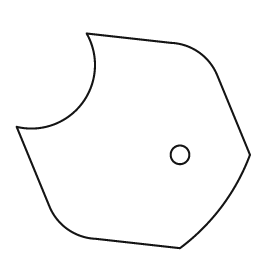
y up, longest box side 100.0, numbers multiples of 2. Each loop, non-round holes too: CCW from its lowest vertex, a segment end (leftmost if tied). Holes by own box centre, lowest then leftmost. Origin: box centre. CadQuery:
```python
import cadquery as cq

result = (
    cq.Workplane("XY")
    .moveTo(20.0, -46.0)
    .threePointArc((38.0, -28.0), (50.0, -6.0))
    .lineTo(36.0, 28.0)
    .threePointArc((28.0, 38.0), (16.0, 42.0))
    .lineTo(-20.0, 46.0)
    .threePointArc((-22.0, 16.0), (-50.0, 6.0))
    .lineTo(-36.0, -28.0)
    .threePointArc((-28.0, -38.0), (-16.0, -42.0))
    .close()
    .moveTo(20.0, -6.0)
    .circle(4.0)
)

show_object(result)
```